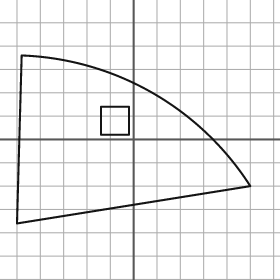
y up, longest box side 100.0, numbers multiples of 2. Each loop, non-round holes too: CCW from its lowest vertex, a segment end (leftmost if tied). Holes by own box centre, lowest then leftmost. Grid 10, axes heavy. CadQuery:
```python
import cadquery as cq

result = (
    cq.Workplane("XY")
    .moveTo(-50.0, -36.0)
    .lineTo(50.0, -20.0)
    .threePointArc((8.0, 20.0), (-48.0, 36.0))
    .close()
    .moveTo(-14.0, 2.0)
    .lineTo(-2.0, 2.0)
    .lineTo(-2.0, 14.0)
    .lineTo(-14.0, 14.0)
    .close()
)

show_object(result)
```